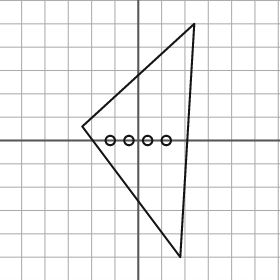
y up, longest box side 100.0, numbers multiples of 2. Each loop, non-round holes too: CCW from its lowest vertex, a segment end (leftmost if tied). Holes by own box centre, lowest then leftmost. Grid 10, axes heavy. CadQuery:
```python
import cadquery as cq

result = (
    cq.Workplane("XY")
    .moveTo(18.0, -50.0)
    .lineTo(24.0, 50.0)
    .lineTo(-24.0, 6.0)
    .close()
    .moveTo(-12.0, 0.0)
    .circle(2.0)
    .moveTo(-4.0, 0.0)
    .circle(2.0)
    .moveTo(4.0, 0.0)
    .circle(2.0)
    .moveTo(12.0, 0.0)
    .circle(2.0)
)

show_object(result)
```